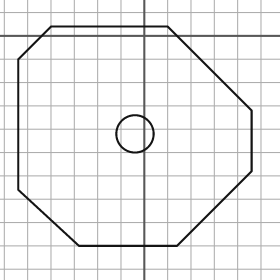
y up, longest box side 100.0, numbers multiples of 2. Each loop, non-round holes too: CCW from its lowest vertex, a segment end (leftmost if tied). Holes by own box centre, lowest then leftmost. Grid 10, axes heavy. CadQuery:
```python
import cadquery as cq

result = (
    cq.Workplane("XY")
    .moveTo(-28.0, -90.0)
    .lineTo(14.0, -90.0)
    .lineTo(46.0, -58.0)
    .lineTo(46.0, -32.0)
    .lineTo(10.0, 4.0)
    .lineTo(-40.0, 4.0)
    .lineTo(-54.0, -10.0)
    .lineTo(-54.0, -66.0)
    .close()
    .moveTo(-4.0, -42.0)
    .circle(8.0)
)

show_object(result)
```